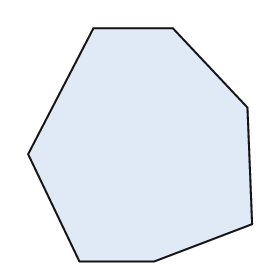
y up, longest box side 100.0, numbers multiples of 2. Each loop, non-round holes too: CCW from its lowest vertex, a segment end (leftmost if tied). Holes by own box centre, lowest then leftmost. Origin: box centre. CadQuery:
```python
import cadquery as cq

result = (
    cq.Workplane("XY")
    .moveTo(-26.0, -50.0)
    .lineTo(6.0, -50.0)
    .lineTo(48.0, -34.0)
    .lineTo(46.0, 16.0)
    .lineTo(14.0, 50.0)
    .lineTo(-20.0, 50.0)
    .lineTo(-48.0, -4.0)
    .close()
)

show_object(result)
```